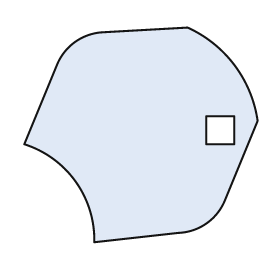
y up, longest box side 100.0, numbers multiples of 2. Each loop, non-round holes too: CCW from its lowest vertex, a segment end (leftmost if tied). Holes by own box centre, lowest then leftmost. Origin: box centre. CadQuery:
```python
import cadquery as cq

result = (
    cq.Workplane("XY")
    .moveTo(-20.0, -46.0)
    .lineTo(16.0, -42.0)
    .threePointArc((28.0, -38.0), (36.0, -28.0))
    .lineTo(50.0, 6.0)
    .threePointArc((40.0, 30.0), (20.0, 46.0))
    .lineTo(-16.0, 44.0)
    .threePointArc((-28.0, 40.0), (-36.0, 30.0))
    .lineTo(-50.0, -4.0)
    .threePointArc((-28.0, -20.0), (-20.0, -46.0))
    .close()
    .moveTo(28.0, -4.0)
    .lineTo(40.0, -4.0)
    .lineTo(40.0, 8.0)
    .lineTo(28.0, 8.0)
    .close()
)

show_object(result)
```